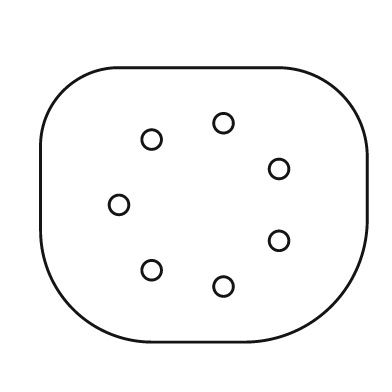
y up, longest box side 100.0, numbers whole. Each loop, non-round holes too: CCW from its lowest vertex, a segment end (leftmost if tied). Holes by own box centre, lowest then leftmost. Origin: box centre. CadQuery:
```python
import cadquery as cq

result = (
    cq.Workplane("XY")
    .moveTo(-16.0, -42.0)
    .lineTo(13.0, -42.0)
    .threePointArc((39.0, -31.0), (50.0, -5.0))
    .lineTo(50.0, 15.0)
    .threePointArc((42.0, 34.0), (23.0, 42.0))
    .lineTo(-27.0, 42.0)
    .threePointArc((-43.0, 35.0), (-50.0, 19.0))
    .lineTo(-50.0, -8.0)
    .threePointArc((-40.0, -32.0), (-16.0, -42.0))
    .close()
    .moveTo(6.0, -25.0)
    .circle(3.0)
    .moveTo(-16.0, -20.0)
    .circle(3.0)
    .moveTo(23.0, -11.0)
    .circle(3.0)
    .moveTo(-26.0, 0.0)
    .circle(3.0)
    .moveTo(23.0, 11.0)
    .circle(3.0)
    .moveTo(-16.0, 20.0)
    .circle(3.0)
    .moveTo(6.0, 25.0)
    .circle(3.0)
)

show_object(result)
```